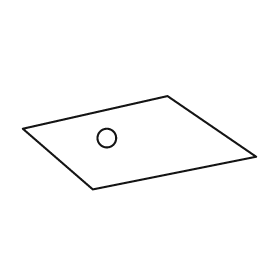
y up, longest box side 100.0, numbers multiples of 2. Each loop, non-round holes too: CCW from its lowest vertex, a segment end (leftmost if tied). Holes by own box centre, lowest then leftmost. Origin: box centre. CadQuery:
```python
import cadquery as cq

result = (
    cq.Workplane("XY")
    .moveTo(-20.0, -20.0)
    .lineTo(50.0, -6.0)
    .lineTo(12.0, 20.0)
    .lineTo(-50.0, 6.0)
    .close()
    .moveTo(-14.0, 2.0)
    .circle(4.0)
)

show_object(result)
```